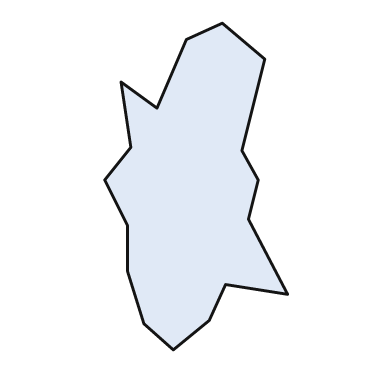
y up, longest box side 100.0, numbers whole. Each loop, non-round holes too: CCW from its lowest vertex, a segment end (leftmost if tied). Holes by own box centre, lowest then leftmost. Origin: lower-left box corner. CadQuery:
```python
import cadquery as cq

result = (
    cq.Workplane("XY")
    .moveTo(21.0, 0.0)
    .lineTo(32.0, 9.0)
    .lineTo(37.0, 20.0)
    .lineTo(56.0, 17.0)
    .lineTo(44.0, 40.0)
    .lineTo(47.0, 52.0)
    .lineTo(42.0, 61.0)
    .lineTo(49.0, 89.0)
    .lineTo(36.0, 100.0)
    .lineTo(25.0, 95.0)
    .lineTo(16.0, 74.0)
    .lineTo(5.0, 82.0)
    .lineTo(8.0, 62.0)
    .lineTo(0.0, 52.0)
    .lineTo(7.0, 38.0)
    .lineTo(7.0, 24.0)
    .lineTo(12.0, 8.0)
    .close()
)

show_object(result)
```